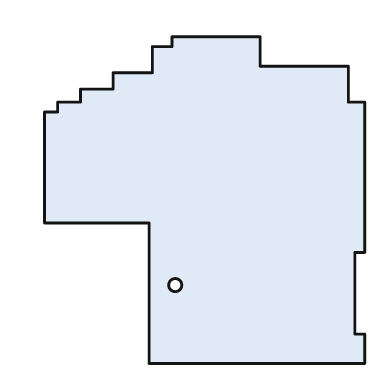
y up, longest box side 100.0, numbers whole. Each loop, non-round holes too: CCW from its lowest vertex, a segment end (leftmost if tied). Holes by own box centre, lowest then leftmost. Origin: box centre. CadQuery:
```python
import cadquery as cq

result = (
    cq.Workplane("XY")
    .moveTo(-17.0, -50.0)
    .lineTo(49.0, -50.0)
    .lineTo(49.0, -41.0)
    .lineTo(46.0, -41.0)
    .lineTo(46.0, -16.0)
    .lineTo(49.0, -16.0)
    .lineTo(49.0, 30.0)
    .lineTo(44.0, 30.0)
    .lineTo(44.0, 41.0)
    .lineTo(17.0, 41.0)
    .lineTo(17.0, 50.0)
    .lineTo(-10.0, 50.0)
    .lineTo(-10.0, 47.0)
    .lineTo(-16.0, 47.0)
    .lineTo(-16.0, 39.0)
    .lineTo(-28.0, 39.0)
    .lineTo(-28.0, 34.0)
    .lineTo(-38.0, 34.0)
    .lineTo(-38.0, 30.0)
    .lineTo(-45.0, 30.0)
    .lineTo(-45.0, 27.0)
    .lineTo(-49.0, 27.0)
    .lineTo(-49.0, -7.0)
    .lineTo(-17.0, -7.0)
    .close()
    .moveTo(-9.0, -26.0)
    .circle(2.0)
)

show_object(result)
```